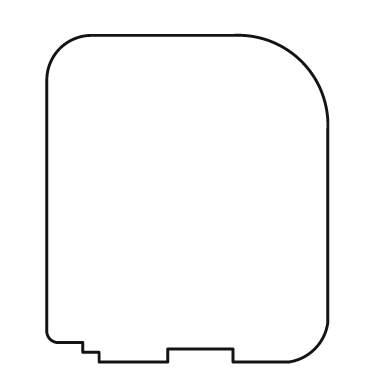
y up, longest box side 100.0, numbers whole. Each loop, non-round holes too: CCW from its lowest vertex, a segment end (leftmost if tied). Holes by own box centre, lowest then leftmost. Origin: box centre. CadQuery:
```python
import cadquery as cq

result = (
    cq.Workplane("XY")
    .moveTo(-27.0, -50.0)
    .lineTo(-6.0, -50.0)
    .lineTo(-6.0, -46.0)
    .lineTo(14.0, -46.0)
    .lineTo(14.0, -50.0)
    .lineTo(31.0, -50.0)
    .threePointArc((39.0, -46.0), (43.0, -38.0))
    .lineTo(43.0, 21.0)
    .threePointArc((35.0, 42.0), (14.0, 50.0))
    .lineTo(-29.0, 50.0)
    .threePointArc((-39.0, 46.0), (-43.0, 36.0))
    .lineTo(-43.0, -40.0)
    .threePointArc((-42.0, -43.0), (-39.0, -44.0))
    .lineTo(-32.0, -44.0)
    .lineTo(-32.0, -47.0)
    .lineTo(-27.0, -47.0)
    .close()
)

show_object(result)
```